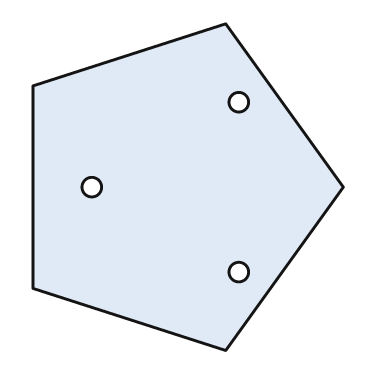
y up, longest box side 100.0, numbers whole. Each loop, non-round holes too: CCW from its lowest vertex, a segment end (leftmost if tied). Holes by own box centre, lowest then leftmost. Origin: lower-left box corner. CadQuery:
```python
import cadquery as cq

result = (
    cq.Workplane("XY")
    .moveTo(59.0, 0.0)
    .lineTo(95.0, 50.0)
    .lineTo(59.0, 100.0)
    .lineTo(0.0, 81.0)
    .lineTo(0.0, 19.0)
    .close()
    .moveTo(63.0, 24.0)
    .circle(3.0)
    .moveTo(18.0, 50.0)
    .circle(3.0)
    .moveTo(63.0, 76.0)
    .circle(3.0)
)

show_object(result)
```